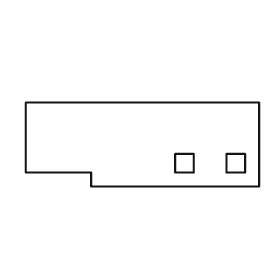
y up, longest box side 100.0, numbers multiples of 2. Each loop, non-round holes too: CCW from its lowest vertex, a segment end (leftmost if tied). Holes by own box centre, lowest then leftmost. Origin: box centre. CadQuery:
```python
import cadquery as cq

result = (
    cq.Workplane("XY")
    .moveTo(-22.0, -18.0)
    .lineTo(50.0, -18.0)
    .lineTo(50.0, 18.0)
    .lineTo(-50.0, 18.0)
    .lineTo(-50.0, -12.0)
    .lineTo(-22.0, -12.0)
    .close()
    .moveTo(14.0, -12.0)
    .lineTo(22.0, -12.0)
    .lineTo(22.0, -4.0)
    .lineTo(14.0, -4.0)
    .close()
    .moveTo(36.0, -12.0)
    .lineTo(44.0, -12.0)
    .lineTo(44.0, -4.0)
    .lineTo(36.0, -4.0)
    .close()
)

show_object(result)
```